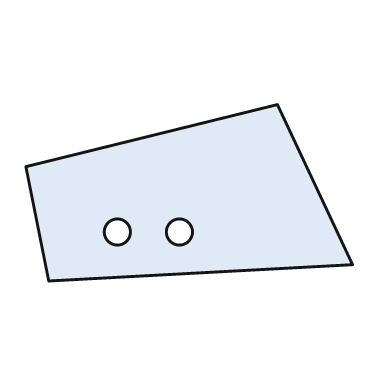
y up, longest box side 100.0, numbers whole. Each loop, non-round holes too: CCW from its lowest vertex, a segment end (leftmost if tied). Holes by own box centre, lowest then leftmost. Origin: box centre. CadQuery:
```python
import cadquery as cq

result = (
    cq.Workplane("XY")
    .moveTo(-43.0, -27.0)
    .lineTo(50.0, -22.0)
    .lineTo(27.0, 27.0)
    .lineTo(-50.0, 8.0)
    .close()
    .moveTo(-22.0, -12.0)
    .circle(4.0)
    .moveTo(-3.0, -12.0)
    .circle(4.0)
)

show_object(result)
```